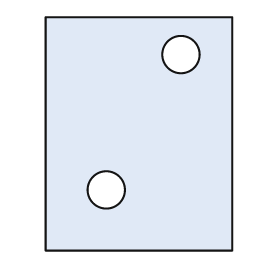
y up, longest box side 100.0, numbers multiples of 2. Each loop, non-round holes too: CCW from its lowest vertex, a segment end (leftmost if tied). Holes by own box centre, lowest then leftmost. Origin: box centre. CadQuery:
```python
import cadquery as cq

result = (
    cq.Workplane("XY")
    .moveTo(-40.0, -50.0)
    .lineTo(40.0, -50.0)
    .lineTo(40.0, 50.0)
    .lineTo(-40.0, 50.0)
    .close()
    .moveTo(-14.0, -24.0)
    .circle(8.0)
    .moveTo(18.0, 34.0)
    .circle(8.0)
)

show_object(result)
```